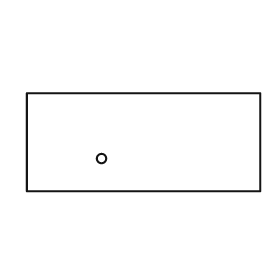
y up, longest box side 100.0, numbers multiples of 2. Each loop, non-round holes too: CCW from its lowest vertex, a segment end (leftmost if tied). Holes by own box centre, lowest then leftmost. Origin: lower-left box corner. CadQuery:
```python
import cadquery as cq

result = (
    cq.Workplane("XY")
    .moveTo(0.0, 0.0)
    .lineTo(100.0, 0.0)
    .lineTo(100.0, 42.0)
    .lineTo(0.0, 42.0)
    .close()
    .moveTo(32.0, 14.0)
    .circle(2.0)
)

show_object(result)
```